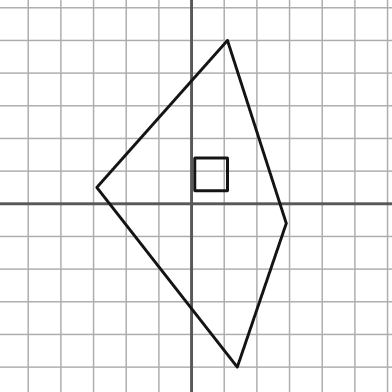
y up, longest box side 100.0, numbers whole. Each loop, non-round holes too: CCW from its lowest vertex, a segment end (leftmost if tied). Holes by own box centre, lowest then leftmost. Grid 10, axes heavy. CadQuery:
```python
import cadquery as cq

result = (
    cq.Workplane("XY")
    .moveTo(14.0, -50.0)
    .lineTo(29.0, -6.0)
    .lineTo(11.0, 50.0)
    .lineTo(-29.0, 5.0)
    .close()
    .moveTo(1.0, 4.0)
    .lineTo(11.0, 4.0)
    .lineTo(11.0, 14.0)
    .lineTo(1.0, 14.0)
    .close()
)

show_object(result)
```